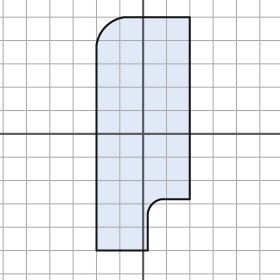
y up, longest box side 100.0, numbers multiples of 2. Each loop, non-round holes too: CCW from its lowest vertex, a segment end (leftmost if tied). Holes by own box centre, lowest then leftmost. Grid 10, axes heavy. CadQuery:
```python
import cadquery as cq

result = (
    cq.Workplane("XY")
    .moveTo(-20.0, -50.0)
    .lineTo(2.0, -50.0)
    .lineTo(2.0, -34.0)
    .threePointArc((4.0, -30.0), (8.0, -28.0))
    .lineTo(20.0, -28.0)
    .lineTo(20.0, 50.0)
    .lineTo(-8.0, 50.0)
    .threePointArc((-16.0, 46.0), (-20.0, 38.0))
    .close()
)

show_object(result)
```